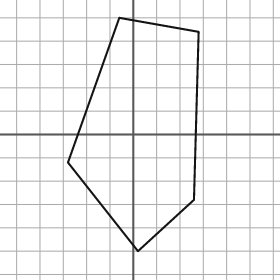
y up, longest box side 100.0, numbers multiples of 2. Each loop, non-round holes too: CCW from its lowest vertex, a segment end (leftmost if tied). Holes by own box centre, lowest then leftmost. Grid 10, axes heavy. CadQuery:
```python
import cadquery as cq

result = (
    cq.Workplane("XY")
    .moveTo(2.0, -50.0)
    .lineTo(26.0, -28.0)
    .lineTo(28.0, 44.0)
    .lineTo(-6.0, 50.0)
    .lineTo(-28.0, -12.0)
    .close()
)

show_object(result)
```